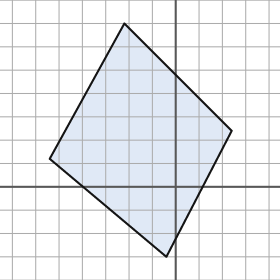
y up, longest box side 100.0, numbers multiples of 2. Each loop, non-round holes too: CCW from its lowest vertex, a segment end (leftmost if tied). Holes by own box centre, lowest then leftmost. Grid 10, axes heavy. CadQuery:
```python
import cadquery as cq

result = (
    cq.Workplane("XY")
    .moveTo(-4.0, -30.0)
    .lineTo(24.0, 24.0)
    .lineTo(-22.0, 70.0)
    .lineTo(-54.0, 12.0)
    .close()
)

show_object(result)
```